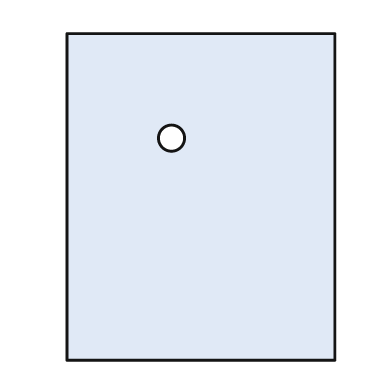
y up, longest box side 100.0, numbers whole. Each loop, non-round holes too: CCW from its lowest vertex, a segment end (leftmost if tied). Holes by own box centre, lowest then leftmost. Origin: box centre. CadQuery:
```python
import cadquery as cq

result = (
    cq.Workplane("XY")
    .moveTo(-41.0, -50.0)
    .lineTo(41.0, -50.0)
    .lineTo(41.0, 50.0)
    .lineTo(-41.0, 50.0)
    .close()
    .moveTo(-9.0, 18.0)
    .circle(4.0)
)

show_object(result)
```